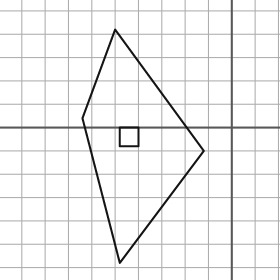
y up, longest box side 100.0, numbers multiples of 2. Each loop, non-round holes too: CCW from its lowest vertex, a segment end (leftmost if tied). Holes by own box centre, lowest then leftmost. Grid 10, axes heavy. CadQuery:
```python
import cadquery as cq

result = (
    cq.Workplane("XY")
    .moveTo(-48.0, -58.0)
    .lineTo(-12.0, -10.0)
    .lineTo(-50.0, 42.0)
    .lineTo(-64.0, 4.0)
    .close()
    .moveTo(-48.0, -8.0)
    .lineTo(-40.0, -8.0)
    .lineTo(-40.0, 0.0)
    .lineTo(-48.0, 0.0)
    .close()
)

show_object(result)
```